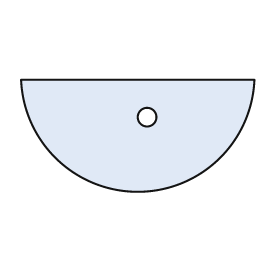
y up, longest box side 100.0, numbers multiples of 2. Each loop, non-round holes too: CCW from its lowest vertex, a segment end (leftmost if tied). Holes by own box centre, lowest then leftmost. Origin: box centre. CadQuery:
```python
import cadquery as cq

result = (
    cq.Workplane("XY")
    .moveTo(-50.0, 24.0)
    .threePointArc((0.0, -24.0), (50.0, 24.0))
    .close()
    .moveTo(4.0, 8.0)
    .circle(4.0)
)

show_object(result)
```